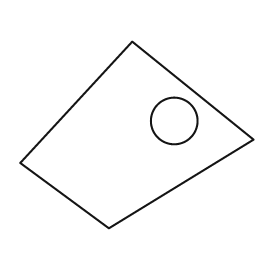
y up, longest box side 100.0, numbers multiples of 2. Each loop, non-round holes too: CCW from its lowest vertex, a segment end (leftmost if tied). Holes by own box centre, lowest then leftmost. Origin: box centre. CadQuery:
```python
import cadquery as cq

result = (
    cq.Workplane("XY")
    .moveTo(-12.0, -40.0)
    .lineTo(50.0, -2.0)
    .lineTo(-2.0, 40.0)
    .lineTo(-50.0, -12.0)
    .close()
    .moveTo(16.0, 6.0)
    .circle(10.0)
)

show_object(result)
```